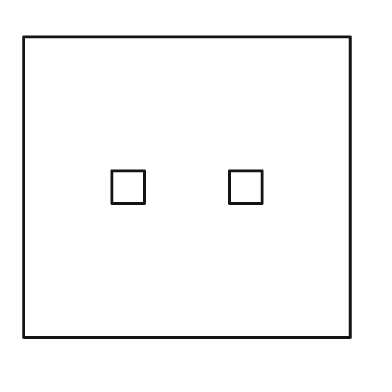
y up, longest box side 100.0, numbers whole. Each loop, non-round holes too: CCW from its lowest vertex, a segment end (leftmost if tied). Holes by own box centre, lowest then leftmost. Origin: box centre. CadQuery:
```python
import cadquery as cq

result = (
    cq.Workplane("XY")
    .moveTo(-50.0, -46.0)
    .lineTo(50.0, -46.0)
    .lineTo(50.0, 46.0)
    .lineTo(-50.0, 46.0)
    .close()
    .moveTo(-23.0, -5.0)
    .lineTo(-13.0, -5.0)
    .lineTo(-13.0, 5.0)
    .lineTo(-23.0, 5.0)
    .close()
    .moveTo(13.0, -5.0)
    .lineTo(23.0, -5.0)
    .lineTo(23.0, 5.0)
    .lineTo(13.0, 5.0)
    .close()
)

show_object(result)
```